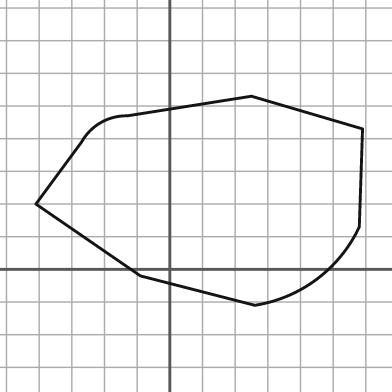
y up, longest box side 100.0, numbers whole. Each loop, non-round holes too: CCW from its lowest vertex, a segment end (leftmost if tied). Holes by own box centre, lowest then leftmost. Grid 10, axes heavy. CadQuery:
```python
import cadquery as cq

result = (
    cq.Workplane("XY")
    .moveTo(26.0, -11.0)
    .threePointArc((45.0, -3.0), (58.0, 13.0))
    .lineTo(59.0, 43.0)
    .lineTo(25.0, 53.0)
    .lineTo(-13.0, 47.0)
    .threePointArc((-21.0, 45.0), (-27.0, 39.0))
    .lineTo(-41.0, 20.0)
    .lineTo(-9.0, -2.0)
    .close()
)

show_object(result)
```